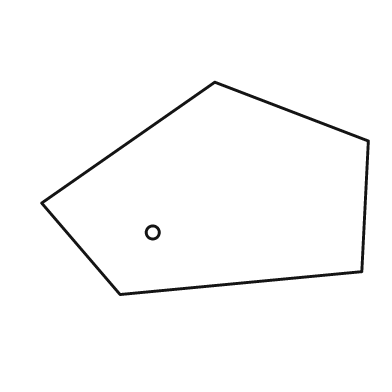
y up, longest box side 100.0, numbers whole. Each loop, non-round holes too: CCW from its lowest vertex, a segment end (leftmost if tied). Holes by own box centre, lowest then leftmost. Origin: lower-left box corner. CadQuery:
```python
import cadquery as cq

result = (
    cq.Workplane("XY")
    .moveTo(24.0, 0.0)
    .lineTo(98.0, 7.0)
    .lineTo(100.0, 47.0)
    .lineTo(53.0, 65.0)
    .lineTo(0.0, 28.0)
    .close()
    .moveTo(34.0, 19.0)
    .circle(2.0)
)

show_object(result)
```